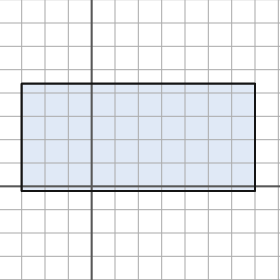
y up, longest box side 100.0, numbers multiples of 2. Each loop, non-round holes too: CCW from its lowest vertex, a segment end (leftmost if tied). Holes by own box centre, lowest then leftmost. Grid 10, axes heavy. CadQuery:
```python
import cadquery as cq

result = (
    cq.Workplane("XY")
    .moveTo(-30.0, -2.0)
    .lineTo(70.0, -2.0)
    .lineTo(70.0, 44.0)
    .lineTo(-30.0, 44.0)
    .close()
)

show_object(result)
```